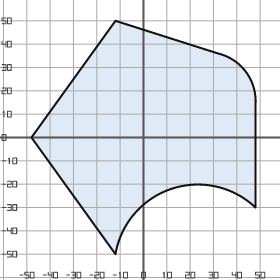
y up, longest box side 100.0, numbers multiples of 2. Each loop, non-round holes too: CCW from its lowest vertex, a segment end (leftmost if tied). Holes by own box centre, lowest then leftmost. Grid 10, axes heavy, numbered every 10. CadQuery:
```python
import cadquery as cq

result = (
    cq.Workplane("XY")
    .moveTo(-12.0, -50.0)
    .threePointArc((12.0, -22.0), (48.0, -30.0))
    .lineTo(48.0, 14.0)
    .threePointArc((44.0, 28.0), (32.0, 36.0))
    .lineTo(-12.0, 50.0)
    .lineTo(-48.0, 0.0)
    .close()
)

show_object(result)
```